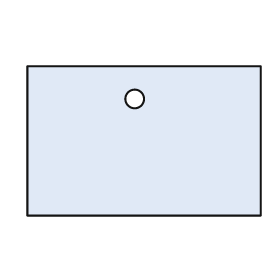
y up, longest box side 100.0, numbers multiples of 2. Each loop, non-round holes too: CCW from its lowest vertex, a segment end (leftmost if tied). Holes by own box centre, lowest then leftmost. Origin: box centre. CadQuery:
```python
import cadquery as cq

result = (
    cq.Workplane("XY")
    .moveTo(-50.0, -32.0)
    .lineTo(50.0, -32.0)
    .lineTo(50.0, 32.0)
    .lineTo(-50.0, 32.0)
    .close()
    .moveTo(-4.0, 18.0)
    .circle(4.0)
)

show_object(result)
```